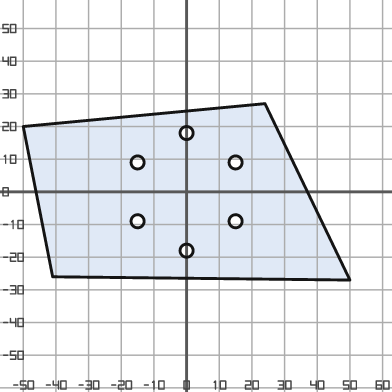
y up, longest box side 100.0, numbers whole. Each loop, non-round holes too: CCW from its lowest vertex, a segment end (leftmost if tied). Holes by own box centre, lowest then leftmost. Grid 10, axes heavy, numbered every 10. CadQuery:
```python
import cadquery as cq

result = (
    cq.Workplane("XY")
    .moveTo(50.0, -27.0)
    .lineTo(24.0, 27.0)
    .lineTo(-50.0, 20.0)
    .lineTo(-41.0, -26.0)
    .close()
    .moveTo(0.0, -18.0)
    .circle(2.0)
    .moveTo(-15.0, -9.0)
    .circle(2.0)
    .moveTo(15.0, -9.0)
    .circle(2.0)
    .moveTo(-15.0, 9.0)
    .circle(2.0)
    .moveTo(15.0, 9.0)
    .circle(2.0)
    .moveTo(0.0, 18.0)
    .circle(2.0)
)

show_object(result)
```